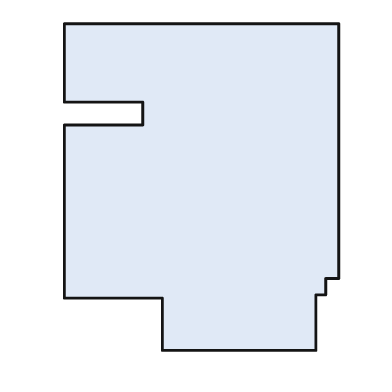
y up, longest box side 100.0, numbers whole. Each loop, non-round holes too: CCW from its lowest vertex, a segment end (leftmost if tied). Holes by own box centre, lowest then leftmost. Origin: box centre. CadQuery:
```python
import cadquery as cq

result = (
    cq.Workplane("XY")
    .moveTo(-12.0, -50.0)
    .lineTo(35.0, -50.0)
    .lineTo(35.0, -33.0)
    .lineTo(38.0, -33.0)
    .lineTo(38.0, -28.0)
    .lineTo(42.0, -28.0)
    .lineTo(42.0, 50.0)
    .lineTo(-42.0, 50.0)
    .lineTo(-42.0, 26.0)
    .lineTo(-18.0, 26.0)
    .lineTo(-18.0, 19.0)
    .lineTo(-42.0, 19.0)
    .lineTo(-42.0, -34.0)
    .lineTo(-12.0, -34.0)
    .close()
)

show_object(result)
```